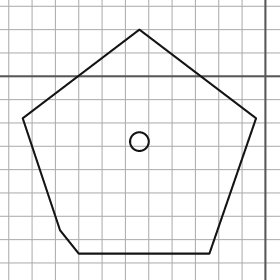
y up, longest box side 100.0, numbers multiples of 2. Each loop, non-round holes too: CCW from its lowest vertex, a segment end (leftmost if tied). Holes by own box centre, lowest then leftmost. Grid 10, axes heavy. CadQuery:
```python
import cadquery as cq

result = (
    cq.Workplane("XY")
    .moveTo(-80.0, -76.0)
    .lineTo(-24.0, -76.0)
    .lineTo(-4.0, -18.0)
    .lineTo(-54.0, 20.0)
    .lineTo(-104.0, -18.0)
    .lineTo(-88.0, -66.0)
    .close()
    .moveTo(-54.0, -28.0)
    .circle(4.0)
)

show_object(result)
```